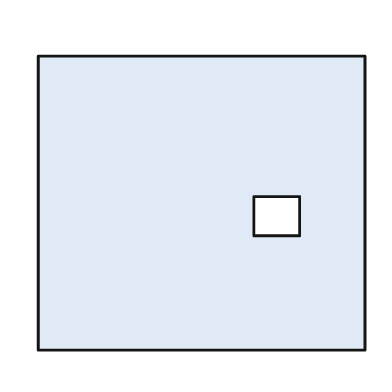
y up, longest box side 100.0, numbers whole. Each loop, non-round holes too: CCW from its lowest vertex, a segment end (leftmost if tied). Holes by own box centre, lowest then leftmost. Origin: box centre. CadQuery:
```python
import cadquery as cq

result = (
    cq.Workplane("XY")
    .moveTo(-50.0, -45.0)
    .lineTo(50.0, -45.0)
    .lineTo(50.0, 45.0)
    .lineTo(-50.0, 45.0)
    .close()
    .moveTo(16.0, -10.0)
    .lineTo(30.0, -10.0)
    .lineTo(30.0, 2.0)
    .lineTo(16.0, 2.0)
    .close()
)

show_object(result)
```